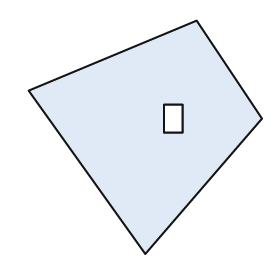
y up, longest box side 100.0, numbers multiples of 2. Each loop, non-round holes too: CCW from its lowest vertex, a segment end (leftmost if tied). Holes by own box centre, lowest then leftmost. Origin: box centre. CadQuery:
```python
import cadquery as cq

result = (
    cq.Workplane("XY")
    .moveTo(0.0, -50.0)
    .lineTo(50.0, 8.0)
    .lineTo(22.0, 50.0)
    .lineTo(-50.0, 20.0)
    .close()
    .moveTo(8.0, 2.0)
    .lineTo(16.0, 2.0)
    .lineTo(16.0, 14.0)
    .lineTo(8.0, 14.0)
    .close()
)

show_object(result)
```